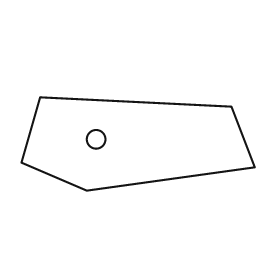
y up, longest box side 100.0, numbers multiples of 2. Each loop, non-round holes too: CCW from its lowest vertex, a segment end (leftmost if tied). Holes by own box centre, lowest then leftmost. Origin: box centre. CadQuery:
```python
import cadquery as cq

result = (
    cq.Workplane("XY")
    .moveTo(-22.0, -20.0)
    .lineTo(50.0, -10.0)
    .lineTo(40.0, 16.0)
    .lineTo(-42.0, 20.0)
    .lineTo(-50.0, -8.0)
    .close()
    .moveTo(-18.0, 2.0)
    .circle(4.0)
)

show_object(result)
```